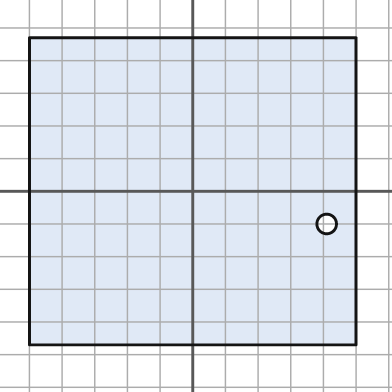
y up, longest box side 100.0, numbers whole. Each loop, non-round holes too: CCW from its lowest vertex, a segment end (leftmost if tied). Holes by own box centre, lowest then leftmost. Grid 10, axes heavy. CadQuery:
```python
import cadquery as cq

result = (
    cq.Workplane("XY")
    .moveTo(-50.0, -47.0)
    .lineTo(50.0, -47.0)
    .lineTo(50.0, 47.0)
    .lineTo(-50.0, 47.0)
    .close()
    .moveTo(41.0, -10.0)
    .circle(3.0)
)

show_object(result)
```